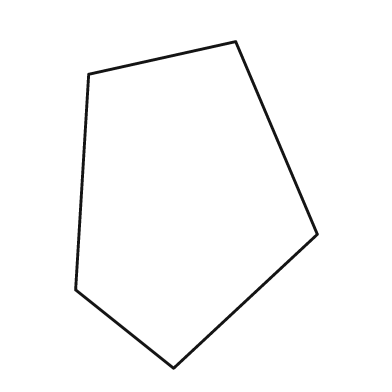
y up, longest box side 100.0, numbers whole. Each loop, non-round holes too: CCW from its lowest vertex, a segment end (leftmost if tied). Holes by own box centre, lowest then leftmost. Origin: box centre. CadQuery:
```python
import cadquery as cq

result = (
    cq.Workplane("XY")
    .moveTo(-7.0, -50.0)
    .lineTo(37.0, -9.0)
    .lineTo(12.0, 50.0)
    .lineTo(-33.0, 40.0)
    .lineTo(-37.0, -26.0)
    .close()
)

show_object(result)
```